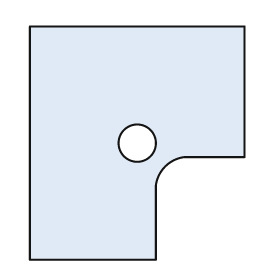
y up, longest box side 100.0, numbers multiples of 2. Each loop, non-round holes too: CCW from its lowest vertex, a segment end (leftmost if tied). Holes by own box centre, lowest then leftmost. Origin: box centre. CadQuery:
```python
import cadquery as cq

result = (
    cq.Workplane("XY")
    .moveTo(-46.0, -50.0)
    .lineTo(8.0, -50.0)
    .lineTo(8.0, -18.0)
    .threePointArc((12.0, -10.0), (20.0, -6.0))
    .lineTo(46.0, -6.0)
    .lineTo(46.0, 50.0)
    .lineTo(-46.0, 50.0)
    .close()
    .moveTo(0.0, 0.0)
    .circle(8.0)
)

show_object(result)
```